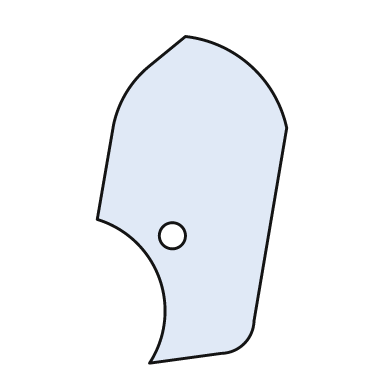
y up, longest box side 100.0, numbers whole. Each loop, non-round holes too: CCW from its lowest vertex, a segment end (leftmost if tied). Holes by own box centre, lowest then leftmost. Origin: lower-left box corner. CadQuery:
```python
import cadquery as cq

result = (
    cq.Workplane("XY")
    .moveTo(16.0, 0.0)
    .lineTo(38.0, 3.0)
    .threePointArc((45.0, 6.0), (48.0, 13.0))
    .lineTo(58.0, 72.0)
    .threePointArc((47.0, 91.0), (27.0, 100.0))
    .lineTo(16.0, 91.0)
    .threePointArc((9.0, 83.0), (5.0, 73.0))
    .lineTo(0.0, 44.0)
    .threePointArc((19.0, 26.0), (16.0, 0.0))
    .close()
    .moveTo(23.0, 39.0)
    .circle(4.0)
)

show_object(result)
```